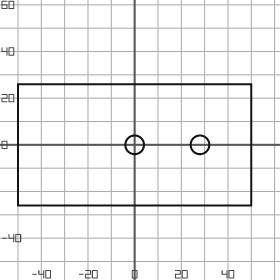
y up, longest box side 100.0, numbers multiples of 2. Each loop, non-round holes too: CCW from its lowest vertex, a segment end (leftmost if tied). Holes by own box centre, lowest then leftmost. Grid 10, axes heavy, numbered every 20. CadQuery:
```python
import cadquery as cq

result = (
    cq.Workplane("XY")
    .moveTo(-50.0, -26.0)
    .lineTo(50.0, -26.0)
    .lineTo(50.0, 26.0)
    .lineTo(-50.0, 26.0)
    .close()
    .moveTo(0.0, 0.0)
    .circle(4.0)
    .moveTo(28.0, 0.0)
    .circle(4.0)
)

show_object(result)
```